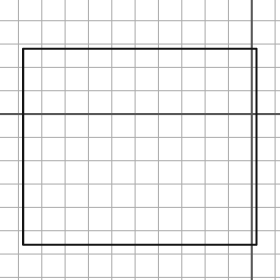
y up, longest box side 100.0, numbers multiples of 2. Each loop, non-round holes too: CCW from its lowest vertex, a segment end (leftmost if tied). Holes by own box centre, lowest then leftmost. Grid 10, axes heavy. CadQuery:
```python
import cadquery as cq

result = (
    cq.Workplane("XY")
    .moveTo(-98.0, -56.0)
    .lineTo(2.0, -56.0)
    .lineTo(2.0, 28.0)
    .lineTo(-98.0, 28.0)
    .close()
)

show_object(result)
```